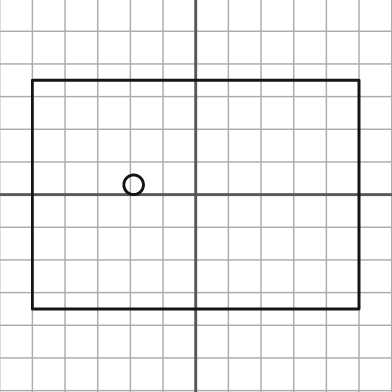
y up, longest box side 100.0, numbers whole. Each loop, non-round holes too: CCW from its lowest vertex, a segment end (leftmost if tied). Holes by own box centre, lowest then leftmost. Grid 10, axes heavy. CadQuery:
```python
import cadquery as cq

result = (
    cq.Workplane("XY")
    .moveTo(-50.0, -35.0)
    .lineTo(50.0, -35.0)
    .lineTo(50.0, 35.0)
    .lineTo(-50.0, 35.0)
    .close()
    .moveTo(-19.0, 3.0)
    .circle(3.0)
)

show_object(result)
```